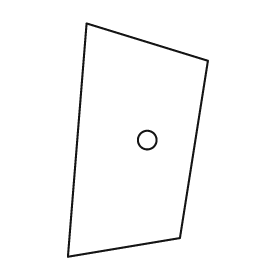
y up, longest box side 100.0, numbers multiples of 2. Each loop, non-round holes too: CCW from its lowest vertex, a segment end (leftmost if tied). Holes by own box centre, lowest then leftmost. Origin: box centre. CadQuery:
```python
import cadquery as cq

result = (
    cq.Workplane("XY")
    .moveTo(-30.0, -50.0)
    .lineTo(18.0, -42.0)
    .lineTo(30.0, 34.0)
    .lineTo(-22.0, 50.0)
    .close()
    .moveTo(4.0, 0.0)
    .circle(4.0)
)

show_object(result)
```